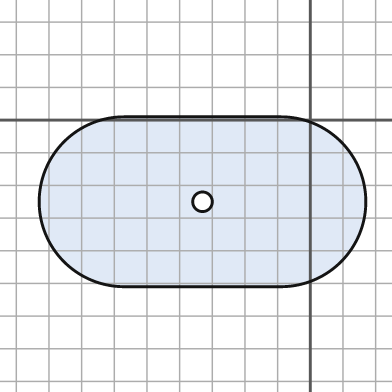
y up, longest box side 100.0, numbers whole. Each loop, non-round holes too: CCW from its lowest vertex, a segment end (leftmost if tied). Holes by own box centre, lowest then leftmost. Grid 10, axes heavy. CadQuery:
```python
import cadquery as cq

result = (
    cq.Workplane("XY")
    .moveTo(-57.0, -51.0)
    .lineTo(-9.0, -51.0)
    .threePointArc((17.0, -25.0), (-9.0, 1.0))
    .lineTo(-57.0, 1.0)
    .threePointArc((-83.0, -25.0), (-57.0, -51.0))
    .close()
    .moveTo(-33.0, -25.0)
    .circle(3.0)
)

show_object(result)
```